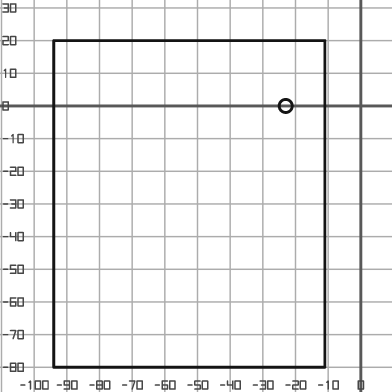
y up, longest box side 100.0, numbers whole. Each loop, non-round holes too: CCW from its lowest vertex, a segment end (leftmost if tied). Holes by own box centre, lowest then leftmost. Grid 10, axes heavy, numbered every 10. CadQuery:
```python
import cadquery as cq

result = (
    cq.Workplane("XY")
    .moveTo(-94.0, -80.0)
    .lineTo(-11.0, -80.0)
    .lineTo(-11.0, 20.0)
    .lineTo(-94.0, 20.0)
    .close()
    .moveTo(-23.0, 0.0)
    .circle(2.0)
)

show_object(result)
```